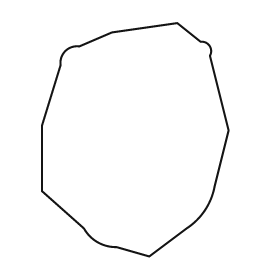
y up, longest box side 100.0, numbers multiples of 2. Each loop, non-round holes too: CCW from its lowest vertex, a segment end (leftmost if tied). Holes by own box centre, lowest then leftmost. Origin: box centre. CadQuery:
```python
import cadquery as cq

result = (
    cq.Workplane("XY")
    .moveTo(6.0, -50.0)
    .lineTo(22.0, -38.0)
    .threePointArc((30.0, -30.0), (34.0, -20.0))
    .lineTo(40.0, 4.0)
    .lineTo(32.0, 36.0)
    .threePointArc((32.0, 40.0), (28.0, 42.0))
    .lineTo(18.0, 50.0)
    .lineTo(-10.0, 46.0)
    .lineTo(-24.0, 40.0)
    .threePointArc((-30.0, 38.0), (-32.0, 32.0))
    .lineTo(-40.0, 6.0)
    .lineTo(-40.0, -22.0)
    .lineTo(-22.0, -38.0)
    .threePointArc((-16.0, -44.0), (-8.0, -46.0))
    .close()
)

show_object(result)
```